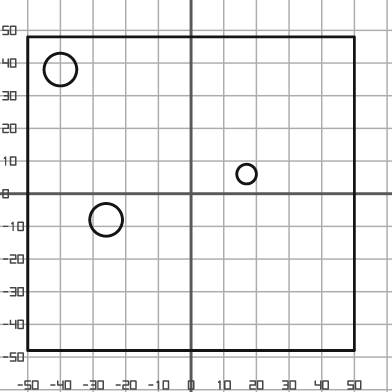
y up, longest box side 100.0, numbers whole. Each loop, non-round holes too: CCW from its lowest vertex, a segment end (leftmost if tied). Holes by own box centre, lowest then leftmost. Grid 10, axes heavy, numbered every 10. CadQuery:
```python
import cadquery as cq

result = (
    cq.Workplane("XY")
    .moveTo(-50.0, -48.0)
    .lineTo(50.0, -48.0)
    .lineTo(50.0, 48.0)
    .lineTo(-50.0, 48.0)
    .close()
    .moveTo(-26.0, -8.0)
    .circle(5.0)
    .moveTo(17.0, 6.0)
    .circle(3.0)
    .moveTo(-40.0, 38.0)
    .circle(5.0)
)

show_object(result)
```